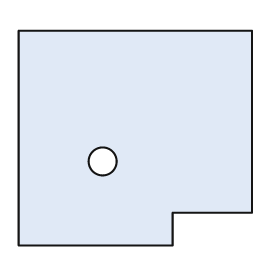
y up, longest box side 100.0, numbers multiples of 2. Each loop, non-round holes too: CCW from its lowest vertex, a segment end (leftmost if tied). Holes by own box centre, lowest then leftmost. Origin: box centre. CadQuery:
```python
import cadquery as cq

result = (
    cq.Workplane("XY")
    .moveTo(-50.0, -46.0)
    .lineTo(16.0, -46.0)
    .lineTo(16.0, -32.0)
    .lineTo(50.0, -32.0)
    .lineTo(50.0, 46.0)
    .lineTo(-50.0, 46.0)
    .close()
    .moveTo(-14.0, -10.0)
    .circle(6.0)
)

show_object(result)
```